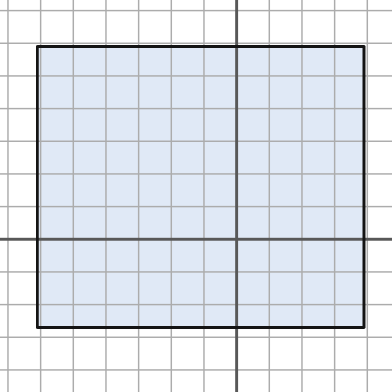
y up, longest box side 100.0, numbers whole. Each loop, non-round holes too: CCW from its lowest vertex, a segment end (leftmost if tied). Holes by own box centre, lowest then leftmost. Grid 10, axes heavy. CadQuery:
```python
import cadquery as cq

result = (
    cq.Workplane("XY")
    .moveTo(-61.0, -27.0)
    .lineTo(39.0, -27.0)
    .lineTo(39.0, 59.0)
    .lineTo(-61.0, 59.0)
    .close()
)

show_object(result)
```